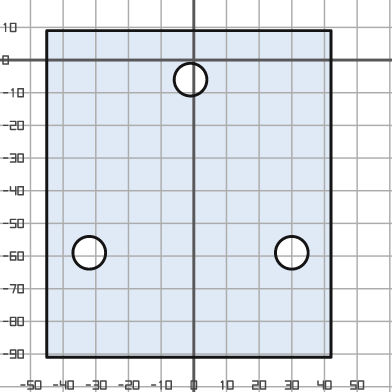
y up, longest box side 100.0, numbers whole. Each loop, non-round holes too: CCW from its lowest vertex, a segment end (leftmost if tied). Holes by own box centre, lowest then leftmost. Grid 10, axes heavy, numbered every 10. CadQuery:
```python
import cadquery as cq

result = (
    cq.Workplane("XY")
    .moveTo(-45.0, -91.0)
    .lineTo(42.0, -91.0)
    .lineTo(42.0, 9.0)
    .lineTo(-45.0, 9.0)
    .close()
    .moveTo(-32.0, -59.0)
    .circle(5.0)
    .moveTo(30.0, -59.0)
    .circle(5.0)
    .moveTo(-1.0, -6.0)
    .circle(5.0)
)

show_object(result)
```